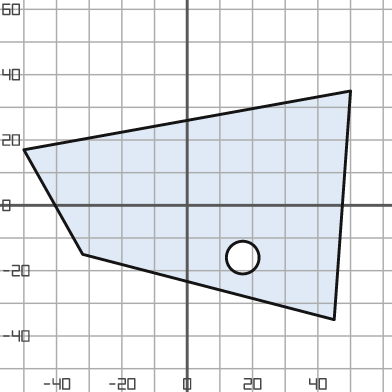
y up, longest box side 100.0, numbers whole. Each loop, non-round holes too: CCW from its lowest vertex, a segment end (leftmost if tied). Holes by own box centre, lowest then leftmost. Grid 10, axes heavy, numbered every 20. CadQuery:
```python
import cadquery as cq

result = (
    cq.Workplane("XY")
    .moveTo(45.0, -35.0)
    .lineTo(50.0, 35.0)
    .lineTo(-50.0, 17.0)
    .lineTo(-32.0, -15.0)
    .close()
    .moveTo(17.0, -16.0)
    .circle(5.0)
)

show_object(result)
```